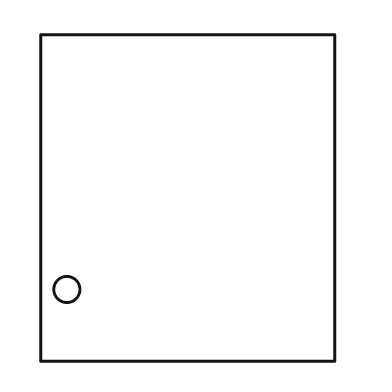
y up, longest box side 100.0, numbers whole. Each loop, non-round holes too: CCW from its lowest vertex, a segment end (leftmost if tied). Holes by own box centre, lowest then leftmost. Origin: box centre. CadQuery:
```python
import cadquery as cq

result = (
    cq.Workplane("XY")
    .moveTo(-45.0, -50.0)
    .lineTo(45.0, -50.0)
    .lineTo(45.0, 50.0)
    .lineTo(-45.0, 50.0)
    .close()
    .moveTo(-37.0, -28.0)
    .circle(4.0)
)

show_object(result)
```